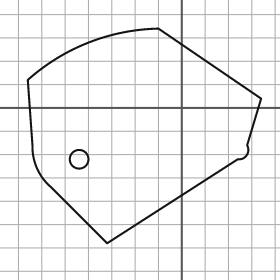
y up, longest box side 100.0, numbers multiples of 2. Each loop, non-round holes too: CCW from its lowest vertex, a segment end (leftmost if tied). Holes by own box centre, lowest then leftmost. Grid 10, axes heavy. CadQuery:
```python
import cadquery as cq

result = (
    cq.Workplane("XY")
    .moveTo(-32.0, -58.0)
    .lineTo(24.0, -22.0)
    .threePointArc((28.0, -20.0), (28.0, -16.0))
    .lineTo(34.0, 4.0)
    .lineTo(-10.0, 34.0)
    .threePointArc((-40.0, 28.0), (-66.0, 12.0))
    .lineTo(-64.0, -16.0)
    .threePointArc((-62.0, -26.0), (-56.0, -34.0))
    .close()
    .moveTo(-44.0, -22.0)
    .circle(4.0)
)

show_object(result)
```